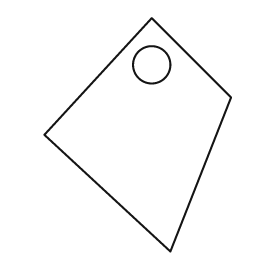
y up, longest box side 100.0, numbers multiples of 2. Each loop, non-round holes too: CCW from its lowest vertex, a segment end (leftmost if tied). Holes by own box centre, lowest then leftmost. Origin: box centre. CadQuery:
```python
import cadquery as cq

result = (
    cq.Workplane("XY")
    .moveTo(14.0, -50.0)
    .lineTo(40.0, 16.0)
    .lineTo(6.0, 50.0)
    .lineTo(-40.0, 0.0)
    .close()
    .moveTo(6.0, 30.0)
    .circle(8.0)
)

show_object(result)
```